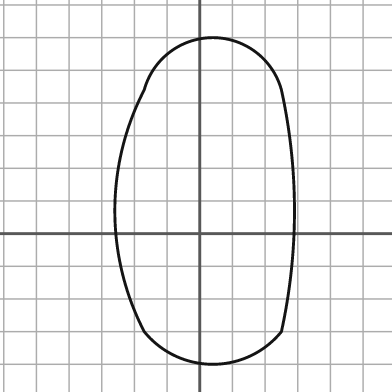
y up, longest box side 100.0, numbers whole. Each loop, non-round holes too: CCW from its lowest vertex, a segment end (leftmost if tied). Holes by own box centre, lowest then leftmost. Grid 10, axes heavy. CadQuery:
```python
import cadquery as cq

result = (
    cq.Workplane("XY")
    .moveTo(-17.0, -30.0)
    .threePointArc((4.0, -40.0), (25.0, -30.0))
    .threePointArc((29.0, 7.0), (25.0, 44.0))
    .threePointArc((4.0, 60.0), (-17.0, 44.0))
    .threePointArc((-26.0, 7.0), (-17.0, -30.0))
    .close()
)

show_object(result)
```